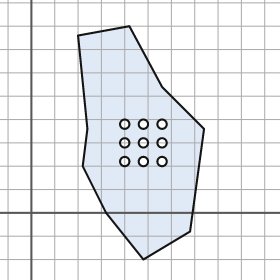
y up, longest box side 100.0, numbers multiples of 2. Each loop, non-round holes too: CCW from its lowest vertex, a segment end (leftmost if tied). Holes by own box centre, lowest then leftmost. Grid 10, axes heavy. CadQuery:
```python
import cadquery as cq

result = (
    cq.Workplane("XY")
    .moveTo(48.0, -20.0)
    .lineTo(68.0, -8.0)
    .lineTo(74.0, 36.0)
    .lineTo(56.0, 54.0)
    .lineTo(42.0, 80.0)
    .lineTo(20.0, 76.0)
    .lineTo(24.0, 36.0)
    .lineTo(22.0, 20.0)
    .lineTo(32.0, 0.0)
    .close()
    .moveTo(40.0, 22.0)
    .circle(2.0)
    .moveTo(48.0, 22.0)
    .circle(2.0)
    .moveTo(56.0, 22.0)
    .circle(2.0)
    .moveTo(40.0, 30.0)
    .circle(2.0)
    .moveTo(48.0, 30.0)
    .circle(2.0)
    .moveTo(56.0, 30.0)
    .circle(2.0)
    .moveTo(40.0, 38.0)
    .circle(2.0)
    .moveTo(48.0, 38.0)
    .circle(2.0)
    .moveTo(56.0, 38.0)
    .circle(2.0)
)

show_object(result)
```